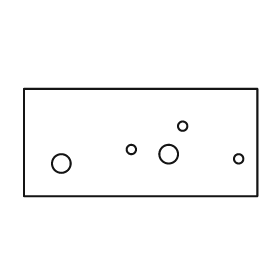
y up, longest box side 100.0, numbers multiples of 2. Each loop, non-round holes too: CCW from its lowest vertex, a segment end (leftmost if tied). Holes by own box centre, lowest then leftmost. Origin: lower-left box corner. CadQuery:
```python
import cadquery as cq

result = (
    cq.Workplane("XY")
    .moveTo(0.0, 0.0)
    .lineTo(100.0, 0.0)
    .lineTo(100.0, 46.0)
    .lineTo(0.0, 46.0)
    .close()
    .moveTo(16.0, 14.0)
    .circle(4.0)
    .moveTo(92.0, 16.0)
    .circle(2.0)
    .moveTo(62.0, 18.0)
    .circle(4.0)
    .moveTo(46.0, 20.0)
    .circle(2.0)
    .moveTo(68.0, 30.0)
    .circle(2.0)
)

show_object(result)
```